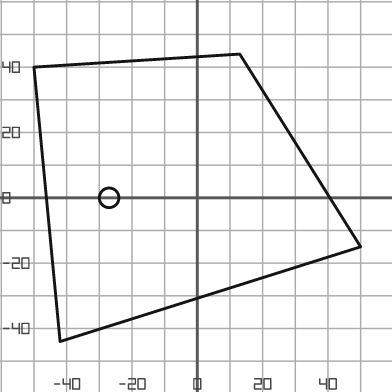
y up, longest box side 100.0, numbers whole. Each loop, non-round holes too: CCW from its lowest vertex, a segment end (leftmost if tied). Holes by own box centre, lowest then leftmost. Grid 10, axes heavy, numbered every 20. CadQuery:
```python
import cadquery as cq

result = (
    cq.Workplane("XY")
    .moveTo(-42.0, -44.0)
    .lineTo(50.0, -15.0)
    .lineTo(13.0, 44.0)
    .lineTo(-50.0, 40.0)
    .close()
    .moveTo(-27.0, 0.0)
    .circle(3.0)
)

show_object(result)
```